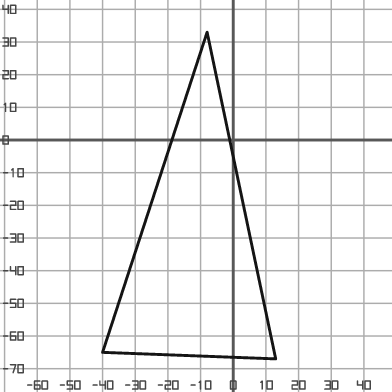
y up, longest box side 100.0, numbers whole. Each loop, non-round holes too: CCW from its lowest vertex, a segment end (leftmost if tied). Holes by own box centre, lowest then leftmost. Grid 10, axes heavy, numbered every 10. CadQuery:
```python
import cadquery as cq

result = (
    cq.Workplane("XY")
    .moveTo(13.0, -67.0)
    .lineTo(-8.0, 33.0)
    .lineTo(-40.0, -65.0)
    .close()
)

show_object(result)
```